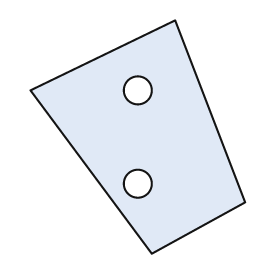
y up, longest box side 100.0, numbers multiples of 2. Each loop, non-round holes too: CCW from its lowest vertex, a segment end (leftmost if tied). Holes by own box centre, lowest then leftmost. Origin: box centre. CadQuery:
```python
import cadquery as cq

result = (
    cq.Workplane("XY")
    .moveTo(6.0, -50.0)
    .lineTo(46.0, -28.0)
    .lineTo(16.0, 50.0)
    .lineTo(-46.0, 20.0)
    .close()
    .moveTo(0.0, -20.0)
    .circle(6.0)
    .moveTo(0.0, 20.0)
    .circle(6.0)
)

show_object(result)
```